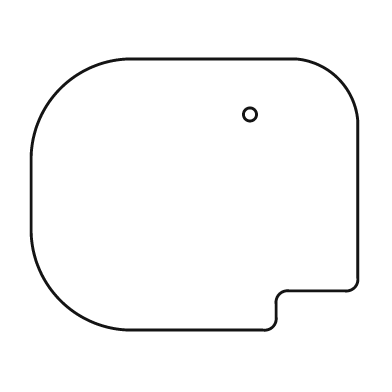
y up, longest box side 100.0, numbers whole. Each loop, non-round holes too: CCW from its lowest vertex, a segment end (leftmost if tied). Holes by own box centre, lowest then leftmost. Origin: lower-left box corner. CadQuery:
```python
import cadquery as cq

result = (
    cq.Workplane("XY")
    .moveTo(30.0, 0.0)
    .lineTo(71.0, 0.0)
    .threePointArc((74.0, 1.0), (75.0, 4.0))
    .lineTo(75.0, 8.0)
    .threePointArc((76.0, 11.0), (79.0, 12.0))
    .lineTo(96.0, 12.0)
    .threePointArc((99.0, 13.0), (100.0, 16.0))
    .lineTo(100.0, 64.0)
    .threePointArc((94.0, 77.0), (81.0, 83.0))
    .lineTo(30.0, 83.0)
    .threePointArc((9.0, 74.0), (0.0, 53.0))
    .lineTo(0.0, 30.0)
    .threePointArc((9.0, 9.0), (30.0, 0.0))
    .close()
    .moveTo(67.0, 66.0)
    .circle(2.0)
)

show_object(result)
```